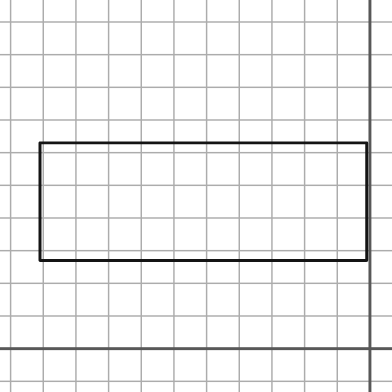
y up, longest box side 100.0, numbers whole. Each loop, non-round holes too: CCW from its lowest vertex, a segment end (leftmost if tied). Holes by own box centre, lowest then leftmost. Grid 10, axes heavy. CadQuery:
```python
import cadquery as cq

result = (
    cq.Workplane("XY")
    .moveTo(-101.0, 27.0)
    .lineTo(-1.0, 27.0)
    .lineTo(-1.0, 63.0)
    .lineTo(-101.0, 63.0)
    .close()
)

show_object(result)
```